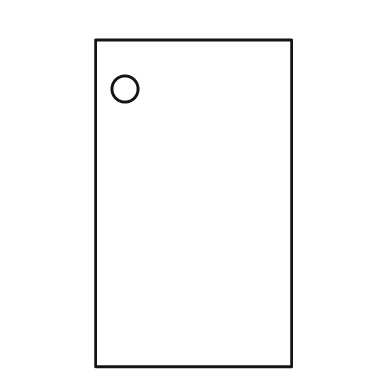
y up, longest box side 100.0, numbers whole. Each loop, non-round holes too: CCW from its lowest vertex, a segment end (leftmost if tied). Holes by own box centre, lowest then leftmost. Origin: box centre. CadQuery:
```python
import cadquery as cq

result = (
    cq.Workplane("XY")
    .moveTo(-30.0, -50.0)
    .lineTo(30.0, -50.0)
    .lineTo(30.0, 50.0)
    .lineTo(-30.0, 50.0)
    .close()
    .moveTo(-21.0, 35.0)
    .circle(4.0)
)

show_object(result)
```